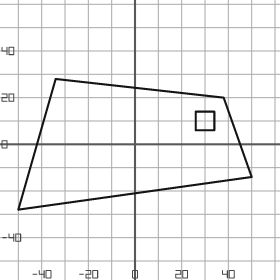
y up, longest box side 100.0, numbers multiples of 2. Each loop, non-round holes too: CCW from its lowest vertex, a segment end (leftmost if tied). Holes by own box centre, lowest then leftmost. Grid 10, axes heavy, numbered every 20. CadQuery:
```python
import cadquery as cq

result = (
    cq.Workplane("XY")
    .moveTo(-50.0, -28.0)
    .lineTo(50.0, -14.0)
    .lineTo(38.0, 20.0)
    .lineTo(-34.0, 28.0)
    .close()
    .moveTo(26.0, 6.0)
    .lineTo(34.0, 6.0)
    .lineTo(34.0, 14.0)
    .lineTo(26.0, 14.0)
    .close()
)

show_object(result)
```